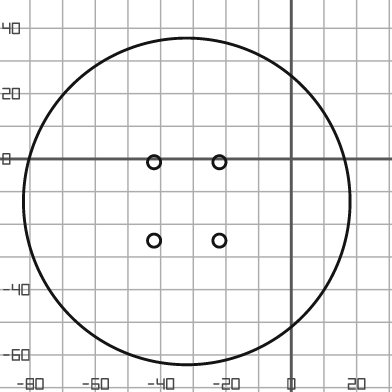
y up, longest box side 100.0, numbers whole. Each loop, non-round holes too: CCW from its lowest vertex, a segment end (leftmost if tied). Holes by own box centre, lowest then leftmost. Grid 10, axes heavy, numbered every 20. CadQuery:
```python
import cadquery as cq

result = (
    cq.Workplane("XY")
    .moveTo(-32.0, -13.0)
    .circle(50.0)
    .moveTo(-42.0, -25.0)
    .circle(2.0)
    .moveTo(-22.0, -25.0)
    .circle(2.0)
    .moveTo(-42.0, -1.0)
    .circle(2.0)
    .moveTo(-22.0, -1.0)
    .circle(2.0)
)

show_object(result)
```